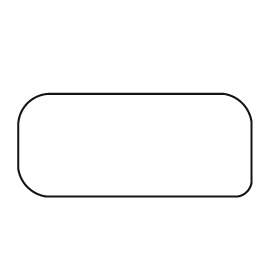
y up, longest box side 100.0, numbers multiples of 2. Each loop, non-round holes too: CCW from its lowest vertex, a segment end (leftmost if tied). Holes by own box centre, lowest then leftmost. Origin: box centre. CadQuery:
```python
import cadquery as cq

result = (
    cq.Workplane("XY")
    .moveTo(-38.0, -22.0)
    .lineTo(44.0, -22.0)
    .threePointArc((48.0, -20.0), (50.0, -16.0))
    .lineTo(50.0, 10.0)
    .threePointArc((46.0, 18.0), (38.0, 22.0))
    .lineTo(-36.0, 22.0)
    .threePointArc((-46.0, 18.0), (-50.0, 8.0))
    .lineTo(-50.0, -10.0)
    .threePointArc((-46.0, -18.0), (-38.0, -22.0))
    .close()
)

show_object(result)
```